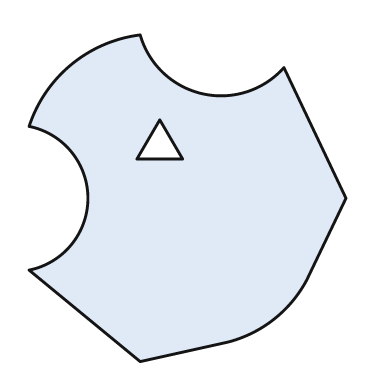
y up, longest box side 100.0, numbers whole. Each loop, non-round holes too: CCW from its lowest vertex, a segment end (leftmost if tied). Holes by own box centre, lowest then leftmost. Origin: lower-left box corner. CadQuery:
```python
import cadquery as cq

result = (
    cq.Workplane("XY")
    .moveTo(34.0, 0.0)
    .lineTo(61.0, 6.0)
    .threePointArc((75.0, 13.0), (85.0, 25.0))
    .lineTo(97.0, 50.0)
    .lineTo(78.0, 90.0)
    .threePointArc((53.0, 82.0), (34.0, 100.0))
    .threePointArc((13.0, 91.0), (0.0, 72.0))
    .threePointArc((18.0, 50.0), (0.0, 28.0))
    .close()
    .moveTo(33.0, 62.0)
    .lineTo(47.0, 62.0)
    .lineTo(40.0, 74.0)
    .close()
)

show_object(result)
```